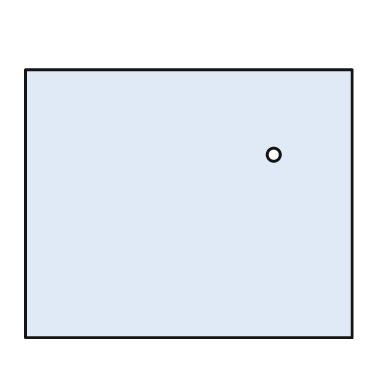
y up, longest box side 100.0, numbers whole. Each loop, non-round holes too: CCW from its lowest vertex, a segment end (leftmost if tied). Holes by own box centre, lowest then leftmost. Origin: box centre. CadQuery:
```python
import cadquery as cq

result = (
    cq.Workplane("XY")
    .moveTo(-50.0, -41.0)
    .lineTo(50.0, -41.0)
    .lineTo(50.0, 41.0)
    .lineTo(-50.0, 41.0)
    .close()
    .moveTo(26.0, 15.0)
    .circle(2.0)
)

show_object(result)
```